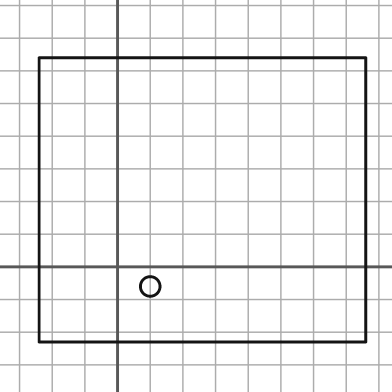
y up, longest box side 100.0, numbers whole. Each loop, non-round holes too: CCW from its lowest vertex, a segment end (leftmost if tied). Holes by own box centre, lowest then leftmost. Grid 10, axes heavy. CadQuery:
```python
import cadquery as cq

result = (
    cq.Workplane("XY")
    .moveTo(-24.0, -23.0)
    .lineTo(76.0, -23.0)
    .lineTo(76.0, 64.0)
    .lineTo(-24.0, 64.0)
    .close()
    .moveTo(10.0, -6.0)
    .circle(3.0)
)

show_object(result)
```